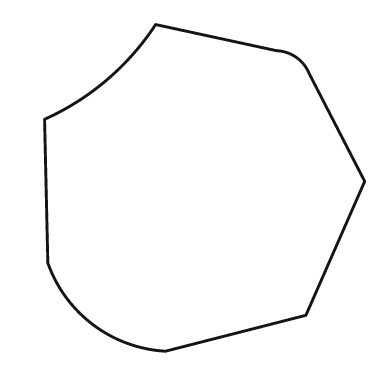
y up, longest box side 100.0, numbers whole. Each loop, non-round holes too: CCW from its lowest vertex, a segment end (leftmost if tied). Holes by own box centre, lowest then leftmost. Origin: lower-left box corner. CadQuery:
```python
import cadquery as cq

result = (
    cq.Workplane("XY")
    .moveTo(37.0, 0.0)
    .lineTo(80.0, 11.0)
    .lineTo(98.0, 52.0)
    .lineTo(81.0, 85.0)
    .threePointArc((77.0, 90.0), (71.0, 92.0))
    .lineTo(34.0, 100.0)
    .threePointArc((19.0, 83.0), (0.0, 71.0))
    .lineTo(1.0, 27.0)
    .threePointArc((15.0, 8.0), (37.0, 0.0))
    .close()
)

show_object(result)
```